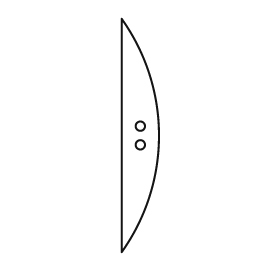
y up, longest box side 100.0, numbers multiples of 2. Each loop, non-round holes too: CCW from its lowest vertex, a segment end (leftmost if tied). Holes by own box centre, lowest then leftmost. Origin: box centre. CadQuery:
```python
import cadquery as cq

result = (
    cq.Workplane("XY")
    .moveTo(-8.0, -50.0)
    .threePointArc((8.0, 0.0), (-8.0, 50.0))
    .close()
    .moveTo(0.0, -4.0)
    .circle(2.0)
    .moveTo(0.0, 4.0)
    .circle(2.0)
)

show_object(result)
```